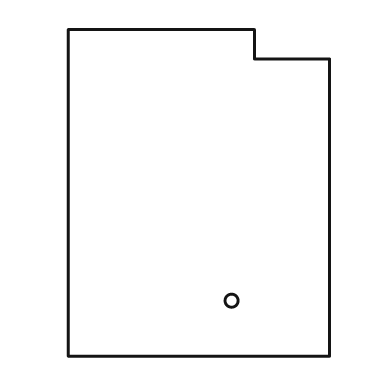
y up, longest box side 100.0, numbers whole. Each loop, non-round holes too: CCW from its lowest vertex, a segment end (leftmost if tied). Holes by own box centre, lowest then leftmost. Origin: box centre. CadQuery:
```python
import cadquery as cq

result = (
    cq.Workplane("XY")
    .moveTo(-40.0, -50.0)
    .lineTo(40.0, -50.0)
    .lineTo(40.0, 41.0)
    .lineTo(17.0, 41.0)
    .lineTo(17.0, 50.0)
    .lineTo(-40.0, 50.0)
    .close()
    .moveTo(10.0, -33.0)
    .circle(2.0)
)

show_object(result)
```